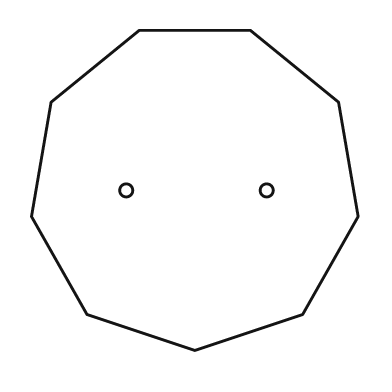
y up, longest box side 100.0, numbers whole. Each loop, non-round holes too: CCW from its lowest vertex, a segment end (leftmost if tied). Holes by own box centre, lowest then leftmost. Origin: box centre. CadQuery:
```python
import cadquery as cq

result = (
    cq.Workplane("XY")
    .moveTo(0.0, -49.0)
    .lineTo(33.0, -38.0)
    .lineTo(50.0, -8.0)
    .lineTo(44.0, 27.0)
    .lineTo(17.0, 49.0)
    .lineTo(-17.0, 49.0)
    .lineTo(-44.0, 27.0)
    .lineTo(-50.0, -8.0)
    .lineTo(-33.0, -38.0)
    .close()
    .moveTo(-21.0, 0.0)
    .circle(2.0)
    .moveTo(22.0, 0.0)
    .circle(2.0)
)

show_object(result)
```